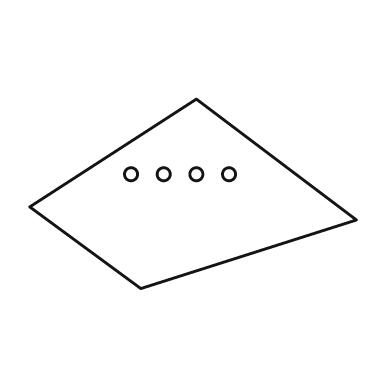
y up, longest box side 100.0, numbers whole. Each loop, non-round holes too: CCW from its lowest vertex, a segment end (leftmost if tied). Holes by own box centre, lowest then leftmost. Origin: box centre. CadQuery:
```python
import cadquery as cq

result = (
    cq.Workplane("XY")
    .moveTo(-16.0, -29.0)
    .lineTo(50.0, -8.0)
    .lineTo(1.0, 29.0)
    .lineTo(-50.0, -4.0)
    .close()
    .moveTo(-19.0, 6.0)
    .circle(2.0)
    .moveTo(-9.0, 6.0)
    .circle(2.0)
    .moveTo(1.0, 6.0)
    .circle(2.0)
    .moveTo(11.0, 6.0)
    .circle(2.0)
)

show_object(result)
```